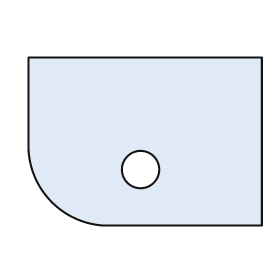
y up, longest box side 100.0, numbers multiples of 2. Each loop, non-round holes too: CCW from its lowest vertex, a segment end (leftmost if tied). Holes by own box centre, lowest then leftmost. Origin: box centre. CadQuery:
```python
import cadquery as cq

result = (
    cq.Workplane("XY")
    .moveTo(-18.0, -36.0)
    .lineTo(50.0, -36.0)
    .lineTo(50.0, 36.0)
    .lineTo(-50.0, 36.0)
    .lineTo(-50.0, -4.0)
    .threePointArc((-40.0, -26.0), (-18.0, -36.0))
    .close()
    .moveTo(-2.0, -12.0)
    .circle(8.0)
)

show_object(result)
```